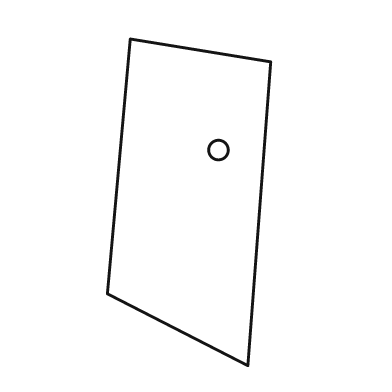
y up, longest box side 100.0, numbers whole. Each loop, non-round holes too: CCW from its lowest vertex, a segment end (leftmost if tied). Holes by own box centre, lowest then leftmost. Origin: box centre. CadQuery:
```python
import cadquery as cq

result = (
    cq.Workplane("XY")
    .moveTo(18.0, -50.0)
    .lineTo(25.0, 43.0)
    .lineTo(-18.0, 50.0)
    .lineTo(-25.0, -28.0)
    .close()
    .moveTo(9.0, 16.0)
    .circle(3.0)
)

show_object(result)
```